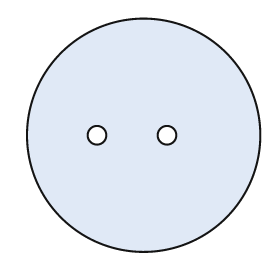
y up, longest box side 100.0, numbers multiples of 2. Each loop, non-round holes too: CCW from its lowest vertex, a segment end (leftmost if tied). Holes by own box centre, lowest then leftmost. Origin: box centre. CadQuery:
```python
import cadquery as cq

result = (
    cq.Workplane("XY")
    .moveTo(0.0, 0.0)
    .circle(50.0)
    .moveTo(-20.0, 0.0)
    .circle(4.0)
    .moveTo(10.0, 0.0)
    .circle(4.0)
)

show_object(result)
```